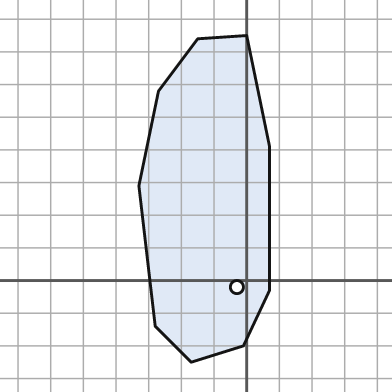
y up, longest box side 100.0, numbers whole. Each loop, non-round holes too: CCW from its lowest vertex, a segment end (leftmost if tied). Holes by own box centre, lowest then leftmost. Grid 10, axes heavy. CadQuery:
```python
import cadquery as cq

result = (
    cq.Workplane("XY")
    .moveTo(-17.0, -25.0)
    .lineTo(-1.0, -20.0)
    .lineTo(7.0, -3.0)
    .lineTo(7.0, 41.0)
    .lineTo(0.0, 75.0)
    .lineTo(-15.0, 74.0)
    .lineTo(-27.0, 58.0)
    .lineTo(-33.0, 29.0)
    .lineTo(-28.0, -14.0)
    .close()
    .moveTo(-3.0, -2.0)
    .circle(2.0)
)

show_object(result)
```